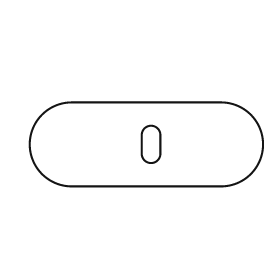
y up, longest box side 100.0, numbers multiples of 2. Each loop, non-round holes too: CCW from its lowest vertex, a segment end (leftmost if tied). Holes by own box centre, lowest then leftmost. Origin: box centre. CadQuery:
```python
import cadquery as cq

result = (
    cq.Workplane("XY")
    .moveTo(-32.0, -18.0)
    .lineTo(32.0, -18.0)
    .threePointArc((50.0, 0.0), (32.0, 18.0))
    .lineTo(-32.0, 18.0)
    .threePointArc((-50.0, 0.0), (-32.0, -18.0))
    .close()
    .moveTo(-2.0, -4.0)
    .threePointArc((2.0, -8.0), (6.0, -4.0))
    .lineTo(6.0, 4.0)
    .threePointArc((2.0, 8.0), (-2.0, 4.0))
    .close()
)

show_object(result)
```